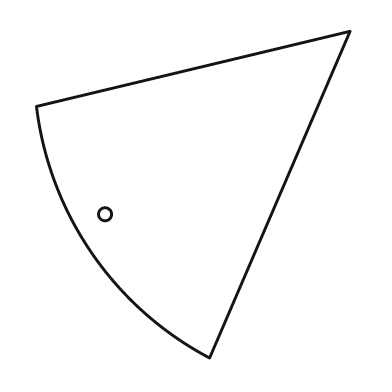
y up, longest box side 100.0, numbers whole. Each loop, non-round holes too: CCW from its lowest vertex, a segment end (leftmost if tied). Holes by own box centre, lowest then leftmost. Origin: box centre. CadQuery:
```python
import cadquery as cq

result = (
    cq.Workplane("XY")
    .moveTo(5.0, -50.0)
    .lineTo(48.0, 50.0)
    .lineTo(-48.0, 27.0)
    .threePointArc((-31.0, -18.0), (5.0, -50.0))
    .close()
    .moveTo(-27.0, -6.0)
    .circle(2.0)
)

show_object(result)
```